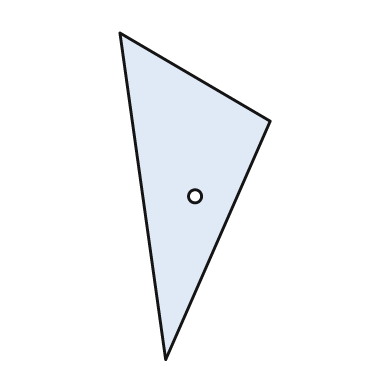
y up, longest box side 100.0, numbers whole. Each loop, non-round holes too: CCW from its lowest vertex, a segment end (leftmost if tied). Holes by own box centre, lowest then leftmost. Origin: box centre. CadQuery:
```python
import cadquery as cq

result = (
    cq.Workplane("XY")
    .moveTo(-9.0, -50.0)
    .lineTo(23.0, 23.0)
    .lineTo(-23.0, 50.0)
    .close()
    .moveTo(0.0, 0.0)
    .circle(2.0)
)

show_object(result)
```